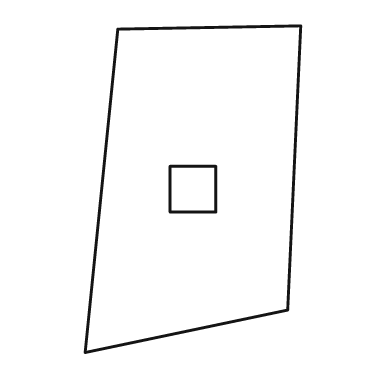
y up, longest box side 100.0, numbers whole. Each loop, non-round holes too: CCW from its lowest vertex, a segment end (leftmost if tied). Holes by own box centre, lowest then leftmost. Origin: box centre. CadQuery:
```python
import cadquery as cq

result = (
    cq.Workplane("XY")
    .moveTo(-33.0, -50.0)
    .lineTo(29.0, -37.0)
    .lineTo(33.0, 50.0)
    .lineTo(-23.0, 49.0)
    .close()
    .moveTo(-7.0, -7.0)
    .lineTo(7.0, -7.0)
    .lineTo(7.0, 7.0)
    .lineTo(-7.0, 7.0)
    .close()
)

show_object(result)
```